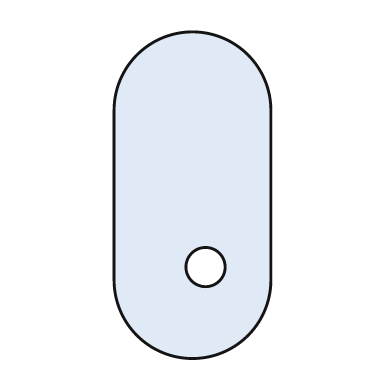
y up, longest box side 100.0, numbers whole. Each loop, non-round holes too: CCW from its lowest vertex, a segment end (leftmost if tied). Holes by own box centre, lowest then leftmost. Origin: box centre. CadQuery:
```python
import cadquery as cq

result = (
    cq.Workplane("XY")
    .moveTo(-24.0, -26.0)
    .threePointArc((0.0, -50.0), (24.0, -26.0))
    .lineTo(24.0, 26.0)
    .threePointArc((0.0, 50.0), (-24.0, 26.0))
    .close()
    .moveTo(4.0, -22.0)
    .circle(6.0)
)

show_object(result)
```